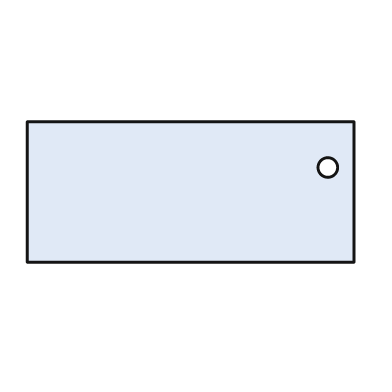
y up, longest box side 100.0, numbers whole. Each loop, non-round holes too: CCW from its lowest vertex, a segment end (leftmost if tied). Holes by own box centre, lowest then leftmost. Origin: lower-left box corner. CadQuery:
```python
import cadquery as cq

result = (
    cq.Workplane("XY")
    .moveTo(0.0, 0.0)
    .lineTo(100.0, 0.0)
    .lineTo(100.0, 43.0)
    .lineTo(0.0, 43.0)
    .close()
    .moveTo(92.0, 29.0)
    .circle(3.0)
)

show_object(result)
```